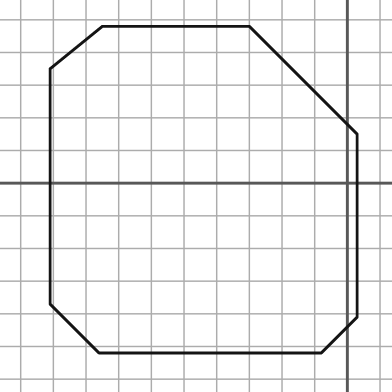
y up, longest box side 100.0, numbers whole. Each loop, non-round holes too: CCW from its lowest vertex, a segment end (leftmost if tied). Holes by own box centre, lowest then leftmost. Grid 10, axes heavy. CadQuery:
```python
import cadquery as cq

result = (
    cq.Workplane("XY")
    .moveTo(-76.0, -52.0)
    .lineTo(-8.0, -52.0)
    .lineTo(3.0, -41.0)
    .lineTo(3.0, 15.0)
    .lineTo(-30.0, 48.0)
    .lineTo(-75.0, 48.0)
    .lineTo(-91.0, 35.0)
    .lineTo(-91.0, -37.0)
    .close()
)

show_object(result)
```